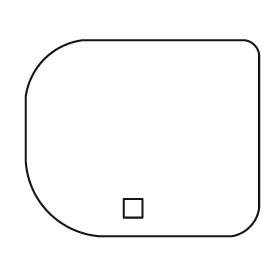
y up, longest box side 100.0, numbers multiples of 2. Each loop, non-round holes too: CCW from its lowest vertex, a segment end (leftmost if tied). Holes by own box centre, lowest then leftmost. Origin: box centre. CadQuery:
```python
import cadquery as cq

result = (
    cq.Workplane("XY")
    .moveTo(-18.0, -42.0)
    .lineTo(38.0, -42.0)
    .threePointArc((46.0, -38.0), (50.0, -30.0))
    .lineTo(50.0, 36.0)
    .threePointArc((48.0, 40.0), (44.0, 42.0))
    .lineTo(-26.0, 42.0)
    .threePointArc((-42.0, 34.0), (-50.0, 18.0))
    .lineTo(-50.0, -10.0)
    .threePointArc((-40.0, -32.0), (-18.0, -42.0))
    .close()
    .moveTo(-8.0, -34.0)
    .lineTo(0.0, -34.0)
    .lineTo(0.0, -26.0)
    .lineTo(-8.0, -26.0)
    .close()
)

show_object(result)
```